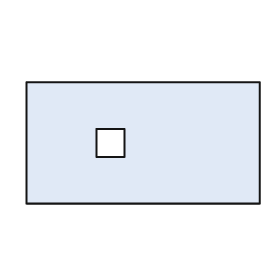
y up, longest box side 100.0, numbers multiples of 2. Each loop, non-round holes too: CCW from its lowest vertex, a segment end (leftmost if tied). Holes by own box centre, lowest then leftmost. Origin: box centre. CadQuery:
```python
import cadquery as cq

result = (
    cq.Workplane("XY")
    .moveTo(-50.0, -26.0)
    .lineTo(50.0, -26.0)
    .lineTo(50.0, 26.0)
    .lineTo(-50.0, 26.0)
    .close()
    .moveTo(-20.0, -6.0)
    .lineTo(-8.0, -6.0)
    .lineTo(-8.0, 6.0)
    .lineTo(-20.0, 6.0)
    .close()
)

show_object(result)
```